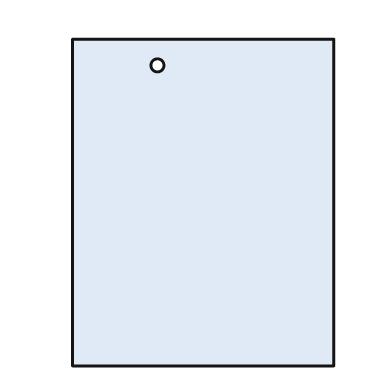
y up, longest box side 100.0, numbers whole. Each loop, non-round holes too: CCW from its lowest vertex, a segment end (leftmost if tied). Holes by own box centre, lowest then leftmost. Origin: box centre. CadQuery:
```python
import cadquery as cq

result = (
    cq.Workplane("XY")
    .moveTo(-40.0, -50.0)
    .lineTo(40.0, -50.0)
    .lineTo(40.0, 50.0)
    .lineTo(-40.0, 50.0)
    .close()
    .moveTo(-14.0, 42.0)
    .circle(2.0)
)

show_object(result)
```